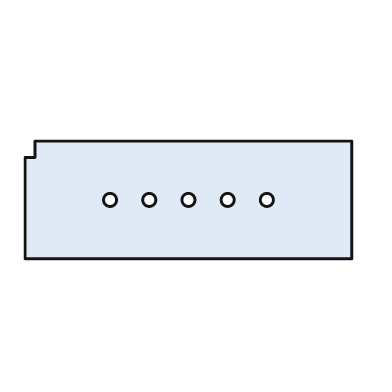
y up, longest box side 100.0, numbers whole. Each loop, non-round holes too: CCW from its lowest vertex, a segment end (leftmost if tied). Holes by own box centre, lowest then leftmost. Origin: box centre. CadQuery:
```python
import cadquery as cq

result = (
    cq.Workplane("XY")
    .moveTo(-50.0, -18.0)
    .lineTo(50.0, -18.0)
    .lineTo(50.0, 18.0)
    .lineTo(-47.0, 18.0)
    .lineTo(-47.0, 13.0)
    .lineTo(-50.0, 13.0)
    .close()
    .moveTo(-24.0, 0.0)
    .circle(2.0)
    .moveTo(-12.0, 0.0)
    .circle(2.0)
    .moveTo(0.0, 0.0)
    .circle(2.0)
    .moveTo(12.0, 0.0)
    .circle(2.0)
    .moveTo(24.0, 0.0)
    .circle(2.0)
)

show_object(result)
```